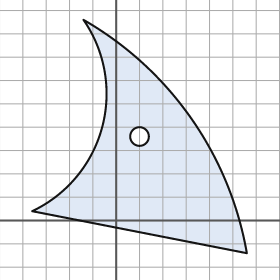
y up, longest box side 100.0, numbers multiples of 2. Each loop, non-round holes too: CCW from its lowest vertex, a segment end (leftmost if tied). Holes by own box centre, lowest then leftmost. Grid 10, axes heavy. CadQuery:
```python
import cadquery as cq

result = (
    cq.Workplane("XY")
    .moveTo(56.0, -14.0)
    .threePointArc((32.0, 44.0), (-14.0, 86.0))
    .threePointArc((-6.0, 40.0), (-36.0, 4.0))
    .close()
    .moveTo(10.0, 36.0)
    .circle(4.0)
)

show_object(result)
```